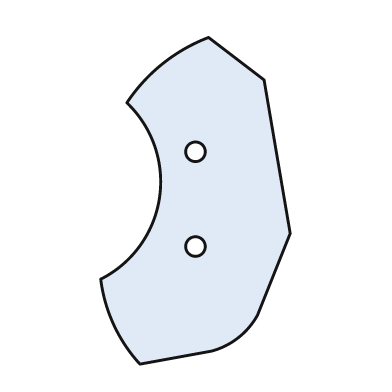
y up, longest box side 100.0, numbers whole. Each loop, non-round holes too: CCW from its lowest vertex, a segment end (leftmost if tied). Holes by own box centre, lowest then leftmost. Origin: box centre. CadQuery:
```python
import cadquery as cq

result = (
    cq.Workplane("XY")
    .moveTo(-17.0, -50.0)
    .lineTo(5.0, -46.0)
    .threePointArc((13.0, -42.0), (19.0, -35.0))
    .lineTo(29.0, -10.0)
    .lineTo(21.0, 37.0)
    .lineTo(4.0, 50.0)
    .threePointArc((-10.0, 42.0), (-21.0, 30.0))
    .threePointArc((-11.0, 1.0), (-29.0, -24.0))
    .threePointArc((-25.0, -38.0), (-17.0, -50.0))
    .close()
    .moveTo(0.0, -14.0)
    .circle(3.0)
    .moveTo(0.0, 15.0)
    .circle(3.0)
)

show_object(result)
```